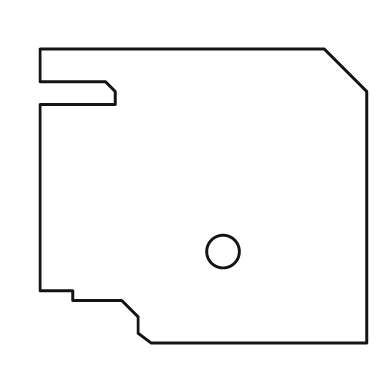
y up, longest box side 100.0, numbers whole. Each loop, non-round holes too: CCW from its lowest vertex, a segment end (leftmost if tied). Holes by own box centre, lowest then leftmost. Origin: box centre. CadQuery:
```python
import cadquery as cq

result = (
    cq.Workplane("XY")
    .moveTo(-16.0, -45.0)
    .lineTo(50.0, -45.0)
    .lineTo(50.0, 32.0)
    .lineTo(37.0, 45.0)
    .lineTo(-50.0, 45.0)
    .lineTo(-50.0, 35.0)
    .lineTo(-30.0, 35.0)
    .lineTo(-27.0, 32.0)
    .lineTo(-27.0, 28.0)
    .lineTo(-50.0, 28.0)
    .lineTo(-50.0, -29.0)
    .lineTo(-40.0, -29.0)
    .lineTo(-40.0, -32.0)
    .lineTo(-25.0, -32.0)
    .lineTo(-20.0, -37.0)
    .lineTo(-20.0, -42.0)
    .close()
    .moveTo(6.0, -17.0)
    .circle(5.0)
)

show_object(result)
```